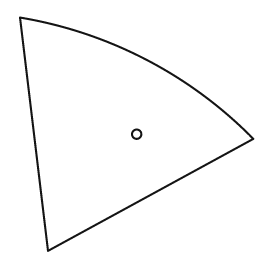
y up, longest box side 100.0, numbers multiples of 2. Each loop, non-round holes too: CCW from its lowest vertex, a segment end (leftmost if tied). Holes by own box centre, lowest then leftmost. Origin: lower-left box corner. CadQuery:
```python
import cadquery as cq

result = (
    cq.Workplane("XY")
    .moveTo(12.0, 0.0)
    .lineTo(100.0, 48.0)
    .threePointArc((54.0, 82.0), (0.0, 100.0))
    .close()
    .moveTo(50.0, 50.0)
    .circle(2.0)
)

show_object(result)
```